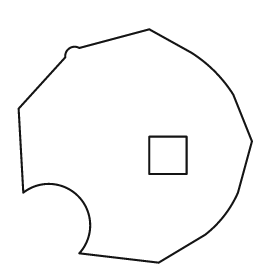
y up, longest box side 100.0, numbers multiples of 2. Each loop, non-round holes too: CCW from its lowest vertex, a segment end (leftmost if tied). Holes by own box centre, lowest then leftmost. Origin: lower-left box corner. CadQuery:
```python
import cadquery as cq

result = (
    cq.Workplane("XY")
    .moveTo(60.0, 0.0)
    .lineTo(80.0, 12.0)
    .threePointArc((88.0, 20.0), (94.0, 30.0))
    .lineTo(100.0, 52.0)
    .lineTo(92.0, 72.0)
    .threePointArc((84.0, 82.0), (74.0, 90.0))
    .lineTo(56.0, 100.0)
    .lineTo(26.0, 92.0)
    .threePointArc((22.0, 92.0), (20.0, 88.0))
    .lineTo(0.0, 66.0)
    .lineTo(2.0, 30.0)
    .threePointArc((26.0, 28.0), (26.0, 4.0))
    .close()
    .moveTo(56.0, 38.0)
    .lineTo(72.0, 38.0)
    .lineTo(72.0, 54.0)
    .lineTo(56.0, 54.0)
    .close()
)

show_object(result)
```